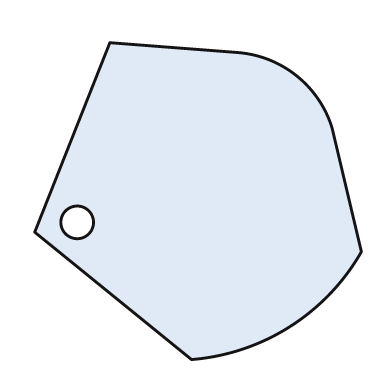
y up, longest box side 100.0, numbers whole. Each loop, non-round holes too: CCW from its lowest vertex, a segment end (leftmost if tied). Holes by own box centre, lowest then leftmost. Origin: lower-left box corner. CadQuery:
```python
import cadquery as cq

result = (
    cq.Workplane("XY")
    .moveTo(48.0, 0.0)
    .threePointArc((78.0, 10.0), (100.0, 33.0))
    .lineTo(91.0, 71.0)
    .threePointArc((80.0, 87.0), (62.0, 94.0))
    .lineTo(23.0, 97.0)
    .lineTo(0.0, 39.0)
    .close()
    .moveTo(13.0, 42.0)
    .circle(5.0)
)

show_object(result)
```